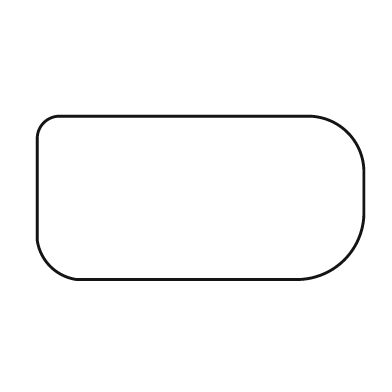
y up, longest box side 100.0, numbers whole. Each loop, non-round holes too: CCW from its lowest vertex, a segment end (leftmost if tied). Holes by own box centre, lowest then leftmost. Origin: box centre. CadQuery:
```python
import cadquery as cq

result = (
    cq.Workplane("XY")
    .moveTo(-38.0, -25.0)
    .lineTo(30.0, -25.0)
    .threePointArc((44.0, -19.0), (50.0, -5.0))
    .lineTo(50.0, 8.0)
    .threePointArc((45.0, 20.0), (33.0, 25.0))
    .lineTo(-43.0, 25.0)
    .threePointArc((-48.0, 23.0), (-50.0, 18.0))
    .lineTo(-50.0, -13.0)
    .threePointArc((-46.0, -21.0), (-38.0, -25.0))
    .close()
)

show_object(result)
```